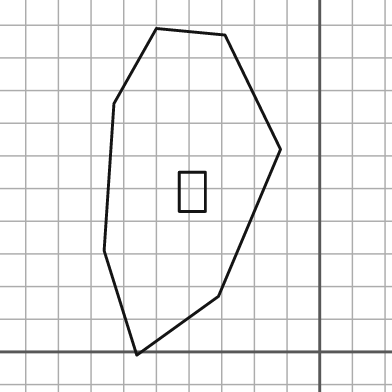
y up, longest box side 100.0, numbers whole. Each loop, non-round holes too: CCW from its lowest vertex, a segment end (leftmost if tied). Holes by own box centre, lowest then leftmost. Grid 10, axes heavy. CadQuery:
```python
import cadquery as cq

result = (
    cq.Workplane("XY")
    .moveTo(-56.0, -1.0)
    .lineTo(-31.0, 17.0)
    .lineTo(-12.0, 62.0)
    .lineTo(-29.0, 97.0)
    .lineTo(-50.0, 99.0)
    .lineTo(-63.0, 76.0)
    .lineTo(-66.0, 31.0)
    .close()
    .moveTo(-43.0, 43.0)
    .lineTo(-35.0, 43.0)
    .lineTo(-35.0, 55.0)
    .lineTo(-43.0, 55.0)
    .close()
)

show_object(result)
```